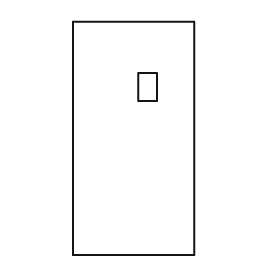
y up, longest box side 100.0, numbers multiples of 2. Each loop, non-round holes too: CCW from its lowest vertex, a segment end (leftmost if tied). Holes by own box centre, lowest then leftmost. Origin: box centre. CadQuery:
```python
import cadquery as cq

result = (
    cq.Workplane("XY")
    .moveTo(-26.0, -50.0)
    .lineTo(26.0, -50.0)
    .lineTo(26.0, 50.0)
    .lineTo(-26.0, 50.0)
    .close()
    .moveTo(2.0, 16.0)
    .lineTo(10.0, 16.0)
    .lineTo(10.0, 28.0)
    .lineTo(2.0, 28.0)
    .close()
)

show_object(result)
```